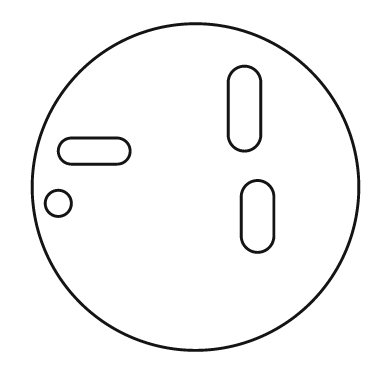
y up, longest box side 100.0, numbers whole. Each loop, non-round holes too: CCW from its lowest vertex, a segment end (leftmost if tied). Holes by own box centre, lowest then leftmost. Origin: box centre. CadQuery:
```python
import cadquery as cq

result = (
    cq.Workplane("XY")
    .moveTo(0.0, 0.0)
    .circle(50.0)
    .moveTo(14.0, -15.0)
    .threePointArc((19.0, -20.0), (24.0, -15.0))
    .lineTo(24.0, -3.0)
    .threePointArc((19.0, 2.0), (14.0, -3.0))
    .close()
    .moveTo(-42.0, -5.0)
    .circle(4.0)
    .moveTo(-38.0, 7.0)
    .lineTo(-24.0, 7.0)
    .threePointArc((-20.0, 11.0), (-24.0, 15.0))
    .lineTo(-38.0, 15.0)
    .threePointArc((-42.0, 11.0), (-38.0, 7.0))
    .close()
    .moveTo(10.0, 16.0)
    .threePointArc((15.0, 11.0), (20.0, 16.0))
    .lineTo(20.0, 32.0)
    .threePointArc((15.0, 37.0), (10.0, 32.0))
    .close()
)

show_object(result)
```